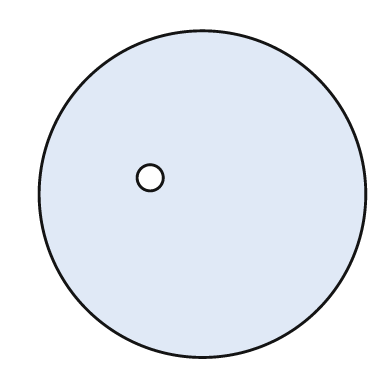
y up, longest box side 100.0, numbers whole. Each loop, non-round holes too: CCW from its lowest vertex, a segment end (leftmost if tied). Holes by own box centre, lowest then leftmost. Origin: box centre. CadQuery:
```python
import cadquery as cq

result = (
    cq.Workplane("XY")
    .moveTo(0.0, 0.0)
    .circle(50.0)
    .moveTo(-16.0, 5.0)
    .circle(4.0)
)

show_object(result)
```